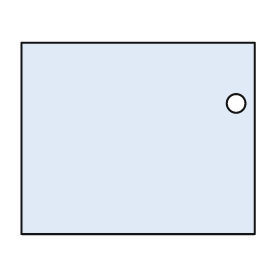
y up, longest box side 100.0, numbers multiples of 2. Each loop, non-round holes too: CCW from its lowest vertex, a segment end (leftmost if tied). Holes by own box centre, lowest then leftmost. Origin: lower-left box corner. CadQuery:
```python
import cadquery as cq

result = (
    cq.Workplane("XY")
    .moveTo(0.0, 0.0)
    .lineTo(100.0, 0.0)
    .lineTo(100.0, 82.0)
    .lineTo(0.0, 82.0)
    .close()
    .moveTo(92.0, 56.0)
    .circle(4.0)
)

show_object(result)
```